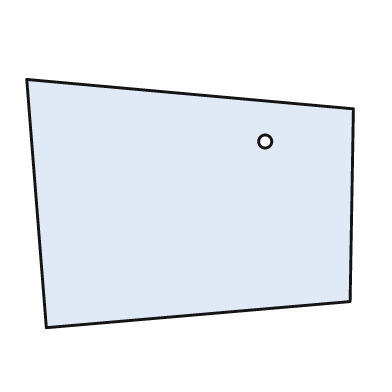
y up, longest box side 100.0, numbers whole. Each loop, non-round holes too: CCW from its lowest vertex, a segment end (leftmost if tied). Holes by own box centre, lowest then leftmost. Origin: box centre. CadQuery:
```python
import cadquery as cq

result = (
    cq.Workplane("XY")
    .moveTo(-44.0, -38.0)
    .lineTo(49.0, -30.0)
    .lineTo(50.0, 29.0)
    .lineTo(-50.0, 38.0)
    .close()
    .moveTo(23.0, 19.0)
    .circle(2.0)
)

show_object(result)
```